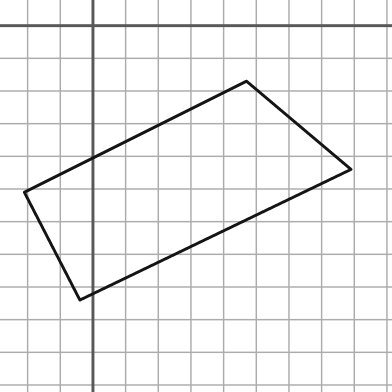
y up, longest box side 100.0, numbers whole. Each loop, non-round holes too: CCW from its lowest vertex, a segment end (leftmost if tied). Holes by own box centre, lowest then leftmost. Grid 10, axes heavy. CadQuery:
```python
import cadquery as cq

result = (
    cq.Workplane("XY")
    .moveTo(-4.0, -84.0)
    .lineTo(79.0, -44.0)
    .lineTo(47.0, -17.0)
    .lineTo(-21.0, -51.0)
    .close()
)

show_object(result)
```